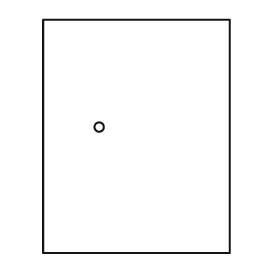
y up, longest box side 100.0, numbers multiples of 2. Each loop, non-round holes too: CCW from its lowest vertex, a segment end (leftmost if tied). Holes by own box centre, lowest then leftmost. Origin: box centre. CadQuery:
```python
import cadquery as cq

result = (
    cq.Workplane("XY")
    .moveTo(-40.0, -50.0)
    .lineTo(40.0, -50.0)
    .lineTo(40.0, 50.0)
    .lineTo(-40.0, 50.0)
    .close()
    .moveTo(-16.0, 4.0)
    .circle(2.0)
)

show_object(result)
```